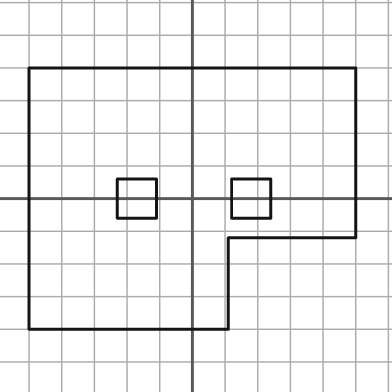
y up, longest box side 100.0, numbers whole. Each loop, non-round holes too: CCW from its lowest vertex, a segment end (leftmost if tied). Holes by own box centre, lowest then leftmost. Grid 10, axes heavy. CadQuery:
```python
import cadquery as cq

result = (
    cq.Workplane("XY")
    .moveTo(-50.0, -40.0)
    .lineTo(11.0, -40.0)
    .lineTo(11.0, -12.0)
    .lineTo(50.0, -12.0)
    .lineTo(50.0, 40.0)
    .lineTo(-50.0, 40.0)
    .close()
    .moveTo(-23.0, -6.0)
    .lineTo(-11.0, -6.0)
    .lineTo(-11.0, 6.0)
    .lineTo(-23.0, 6.0)
    .close()
    .moveTo(12.0, -6.0)
    .lineTo(24.0, -6.0)
    .lineTo(24.0, 6.0)
    .lineTo(12.0, 6.0)
    .close()
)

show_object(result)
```